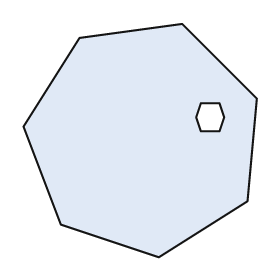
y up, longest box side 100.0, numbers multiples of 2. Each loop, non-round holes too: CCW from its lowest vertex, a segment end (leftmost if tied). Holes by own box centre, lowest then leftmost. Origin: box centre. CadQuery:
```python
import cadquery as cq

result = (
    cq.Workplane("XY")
    .moveTo(8.0, -50.0)
    .lineTo(46.0, -26.0)
    .lineTo(50.0, 18.0)
    .lineTo(18.0, 50.0)
    .lineTo(-26.0, 44.0)
    .lineTo(-50.0, 6.0)
    .lineTo(-34.0, -36.0)
    .close()
    .moveTo(26.0, 4.0)
    .lineTo(34.0, 4.0)
    .lineTo(36.0, 10.0)
    .lineTo(34.0, 16.0)
    .lineTo(26.0, 16.0)
    .lineTo(24.0, 10.0)
    .close()
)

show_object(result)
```